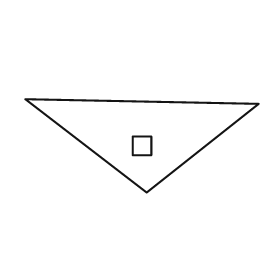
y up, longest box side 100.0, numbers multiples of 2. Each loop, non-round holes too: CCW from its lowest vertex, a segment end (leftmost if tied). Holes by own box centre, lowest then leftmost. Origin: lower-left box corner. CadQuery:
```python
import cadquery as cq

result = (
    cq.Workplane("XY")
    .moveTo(52.0, 0.0)
    .lineTo(100.0, 38.0)
    .lineTo(0.0, 40.0)
    .close()
    .moveTo(46.0, 16.0)
    .lineTo(54.0, 16.0)
    .lineTo(54.0, 24.0)
    .lineTo(46.0, 24.0)
    .close()
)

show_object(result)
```